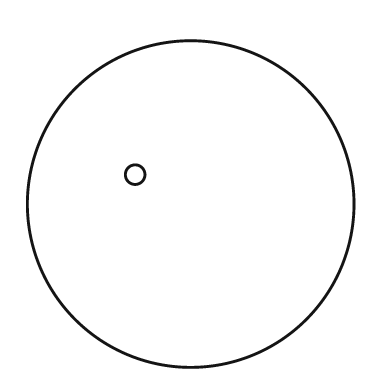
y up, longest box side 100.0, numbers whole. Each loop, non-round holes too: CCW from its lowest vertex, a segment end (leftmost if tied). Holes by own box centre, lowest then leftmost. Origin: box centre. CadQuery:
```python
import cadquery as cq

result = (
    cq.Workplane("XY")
    .moveTo(0.0, 0.0)
    .circle(50.0)
    .moveTo(-17.0, 9.0)
    .circle(3.0)
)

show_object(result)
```